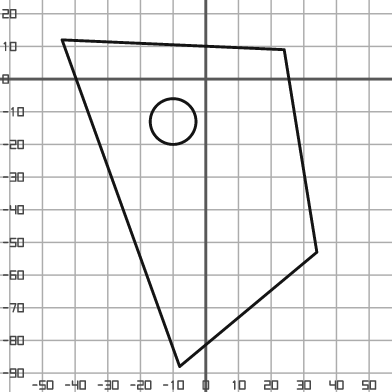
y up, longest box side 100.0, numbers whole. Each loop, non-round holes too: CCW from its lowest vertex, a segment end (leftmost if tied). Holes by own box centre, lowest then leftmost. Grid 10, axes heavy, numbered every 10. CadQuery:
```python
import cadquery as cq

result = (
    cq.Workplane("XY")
    .moveTo(-8.0, -88.0)
    .lineTo(34.0, -53.0)
    .lineTo(24.0, 9.0)
    .lineTo(-44.0, 12.0)
    .close()
    .moveTo(-10.0, -13.0)
    .circle(7.0)
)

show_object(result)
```